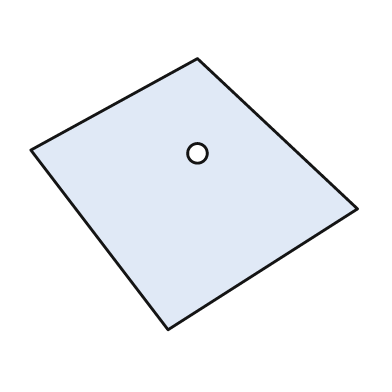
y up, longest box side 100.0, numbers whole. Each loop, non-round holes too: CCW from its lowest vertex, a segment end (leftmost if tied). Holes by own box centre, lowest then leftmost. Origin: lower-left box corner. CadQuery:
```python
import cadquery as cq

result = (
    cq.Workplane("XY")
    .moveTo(42.0, 0.0)
    .lineTo(100.0, 37.0)
    .lineTo(51.0, 83.0)
    .lineTo(0.0, 55.0)
    .close()
    .moveTo(51.0, 54.0)
    .circle(3.0)
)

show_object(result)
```